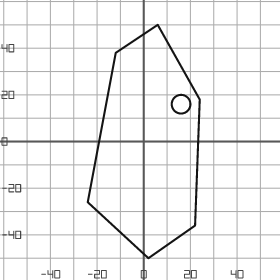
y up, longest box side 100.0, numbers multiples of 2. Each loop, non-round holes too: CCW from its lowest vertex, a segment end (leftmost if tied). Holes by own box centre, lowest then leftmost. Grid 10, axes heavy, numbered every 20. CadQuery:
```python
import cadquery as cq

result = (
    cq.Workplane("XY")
    .moveTo(2.0, -50.0)
    .lineTo(22.0, -36.0)
    .lineTo(24.0, 18.0)
    .lineTo(6.0, 50.0)
    .lineTo(-12.0, 38.0)
    .lineTo(-24.0, -26.0)
    .close()
    .moveTo(16.0, 16.0)
    .circle(4.0)
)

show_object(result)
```